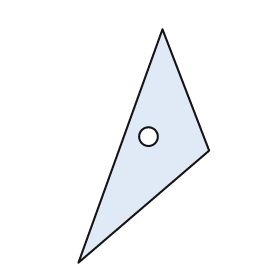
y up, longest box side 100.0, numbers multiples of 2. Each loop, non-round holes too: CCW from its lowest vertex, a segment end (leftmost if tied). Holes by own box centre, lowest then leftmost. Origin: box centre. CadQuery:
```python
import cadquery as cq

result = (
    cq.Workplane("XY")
    .moveTo(-28.0, -50.0)
    .lineTo(28.0, -2.0)
    .lineTo(8.0, 50.0)
    .close()
    .moveTo(2.0, 4.0)
    .circle(4.0)
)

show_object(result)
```